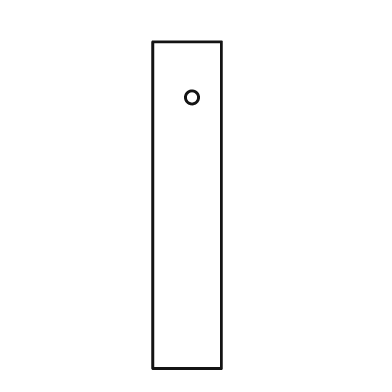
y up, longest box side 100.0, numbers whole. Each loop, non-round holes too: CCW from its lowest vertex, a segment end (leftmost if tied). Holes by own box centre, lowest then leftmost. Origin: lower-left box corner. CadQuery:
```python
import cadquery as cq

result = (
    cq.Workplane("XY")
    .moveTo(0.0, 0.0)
    .lineTo(21.0, 0.0)
    .lineTo(21.0, 100.0)
    .lineTo(0.0, 100.0)
    .close()
    .moveTo(12.0, 83.0)
    .circle(2.0)
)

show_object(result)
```